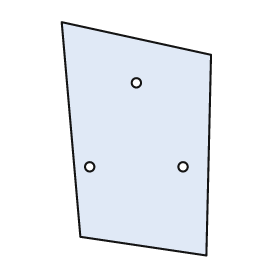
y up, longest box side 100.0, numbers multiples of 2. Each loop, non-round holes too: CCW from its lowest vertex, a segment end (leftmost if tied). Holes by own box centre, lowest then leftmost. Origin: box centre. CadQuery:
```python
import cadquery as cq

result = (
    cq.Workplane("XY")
    .moveTo(30.0, -50.0)
    .lineTo(32.0, 36.0)
    .lineTo(-32.0, 50.0)
    .lineTo(-24.0, -42.0)
    .close()
    .moveTo(-20.0, -12.0)
    .circle(2.0)
    .moveTo(20.0, -12.0)
    .circle(2.0)
    .moveTo(0.0, 24.0)
    .circle(2.0)
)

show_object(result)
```